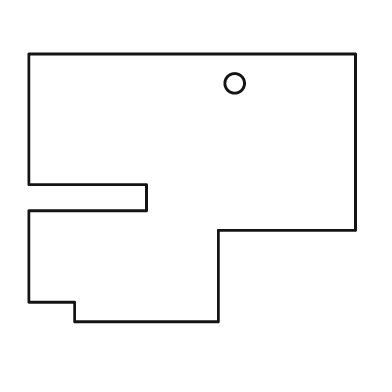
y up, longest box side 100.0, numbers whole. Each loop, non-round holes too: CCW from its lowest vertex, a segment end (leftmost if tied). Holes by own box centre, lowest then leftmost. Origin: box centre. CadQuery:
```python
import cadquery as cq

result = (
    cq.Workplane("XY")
    .moveTo(-36.0, -41.0)
    .lineTo(8.0, -41.0)
    .lineTo(8.0, -13.0)
    .lineTo(50.0, -13.0)
    .lineTo(50.0, 41.0)
    .lineTo(-50.0, 41.0)
    .lineTo(-50.0, 1.0)
    .lineTo(-14.0, 1.0)
    .lineTo(-14.0, -7.0)
    .lineTo(-50.0, -7.0)
    .lineTo(-50.0, -35.0)
    .lineTo(-36.0, -35.0)
    .close()
    .moveTo(13.0, 32.0)
    .circle(3.0)
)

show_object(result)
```